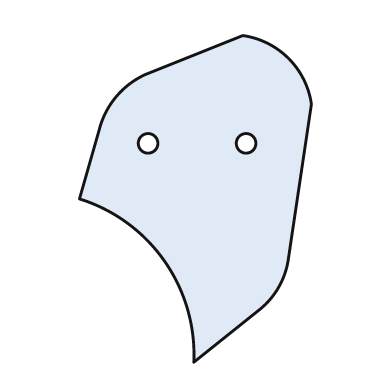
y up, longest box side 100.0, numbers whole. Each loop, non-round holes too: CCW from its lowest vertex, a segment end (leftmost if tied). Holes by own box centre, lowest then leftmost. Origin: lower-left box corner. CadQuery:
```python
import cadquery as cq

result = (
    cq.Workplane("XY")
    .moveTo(35.0, 0.0)
    .lineTo(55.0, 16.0)
    .threePointArc((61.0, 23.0), (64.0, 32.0))
    .lineTo(71.0, 79.0)
    .threePointArc((64.0, 93.0), (50.0, 100.0))
    .lineTo(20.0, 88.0)
    .threePointArc((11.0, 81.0), (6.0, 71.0))
    .lineTo(0.0, 50.0)
    .threePointArc((26.0, 31.0), (35.0, 0.0))
    .close()
    .moveTo(21.0, 67.0)
    .circle(3.0)
    .moveTo(51.0, 67.0)
    .circle(3.0)
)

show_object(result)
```